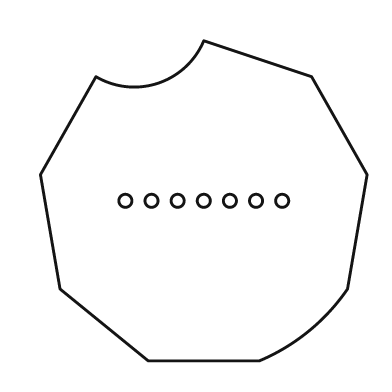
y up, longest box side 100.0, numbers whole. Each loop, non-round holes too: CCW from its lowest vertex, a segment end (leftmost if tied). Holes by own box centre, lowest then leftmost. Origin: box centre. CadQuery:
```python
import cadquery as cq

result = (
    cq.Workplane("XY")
    .moveTo(-17.0, -49.0)
    .lineTo(17.0, -49.0)
    .threePointArc((32.0, -40.0), (44.0, -27.0))
    .lineTo(50.0, 8.0)
    .lineTo(33.0, 38.0)
    .lineTo(0.0, 49.0)
    .threePointArc((-14.0, 36.0), (-33.0, 38.0))
    .lineTo(-50.0, 8.0)
    .lineTo(-44.0, -27.0)
    .close()
    .moveTo(-24.0, 0.0)
    .circle(2.0)
    .moveTo(-16.0, 0.0)
    .circle(2.0)
    .moveTo(-8.0, 0.0)
    .circle(2.0)
    .moveTo(0.0, 0.0)
    .circle(2.0)
    .moveTo(8.0, 0.0)
    .circle(2.0)
    .moveTo(16.0, 0.0)
    .circle(2.0)
    .moveTo(24.0, 0.0)
    .circle(2.0)
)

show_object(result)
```